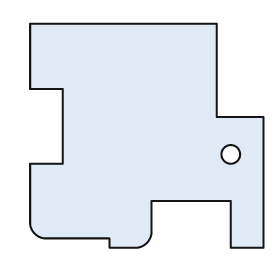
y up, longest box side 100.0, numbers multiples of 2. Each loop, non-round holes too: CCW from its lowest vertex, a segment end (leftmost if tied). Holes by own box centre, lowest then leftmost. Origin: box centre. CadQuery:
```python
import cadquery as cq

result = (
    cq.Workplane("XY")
    .moveTo(-16.0, -48.0)
    .lineTo(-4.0, -48.0)
    .threePointArc((0.0, -46.0), (2.0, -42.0))
    .lineTo(2.0, -28.0)
    .lineTo(36.0, -28.0)
    .lineTo(36.0, -48.0)
    .lineTo(50.0, -48.0)
    .lineTo(50.0, 8.0)
    .lineTo(30.0, 8.0)
    .lineTo(30.0, 48.0)
    .lineTo(-50.0, 48.0)
    .lineTo(-50.0, 20.0)
    .lineTo(-36.0, 20.0)
    .lineTo(-36.0, -12.0)
    .lineTo(-50.0, -12.0)
    .lineTo(-50.0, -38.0)
    .threePointArc((-48.0, -42.0), (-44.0, -44.0))
    .lineTo(-16.0, -44.0)
    .close()
    .moveTo(36.0, -8.0)
    .circle(4.0)
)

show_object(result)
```